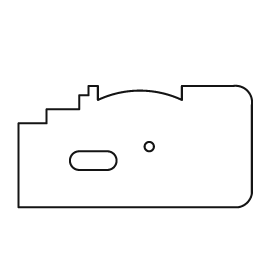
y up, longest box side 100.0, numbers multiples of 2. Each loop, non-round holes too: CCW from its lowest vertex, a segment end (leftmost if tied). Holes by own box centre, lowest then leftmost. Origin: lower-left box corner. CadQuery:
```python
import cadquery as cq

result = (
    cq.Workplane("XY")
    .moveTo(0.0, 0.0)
    .lineTo(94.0, 0.0)
    .threePointArc((98.0, 2.0), (100.0, 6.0))
    .lineTo(100.0, 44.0)
    .threePointArc((98.0, 50.0), (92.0, 52.0))
    .lineTo(70.0, 52.0)
    .lineTo(70.0, 46.0)
    .threePointArc((52.0, 50.0), (34.0, 46.0))
    .lineTo(34.0, 52.0)
    .lineTo(30.0, 52.0)
    .lineTo(30.0, 48.0)
    .lineTo(26.0, 48.0)
    .lineTo(26.0, 42.0)
    .lineTo(12.0, 42.0)
    .lineTo(12.0, 36.0)
    .lineTo(0.0, 36.0)
    .close()
    .moveTo(26.0, 16.0)
    .lineTo(38.0, 16.0)
    .threePointArc((42.0, 20.0), (38.0, 24.0))
    .lineTo(26.0, 24.0)
    .threePointArc((22.0, 20.0), (26.0, 16.0))
    .close()
    .moveTo(56.0, 26.0)
    .circle(2.0)
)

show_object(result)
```